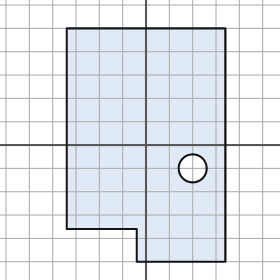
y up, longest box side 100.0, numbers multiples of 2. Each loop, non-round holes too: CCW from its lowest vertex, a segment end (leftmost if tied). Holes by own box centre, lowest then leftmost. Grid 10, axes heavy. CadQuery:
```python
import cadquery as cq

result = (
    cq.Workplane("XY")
    .moveTo(-4.0, -50.0)
    .lineTo(34.0, -50.0)
    .lineTo(34.0, 50.0)
    .lineTo(-34.0, 50.0)
    .lineTo(-34.0, -36.0)
    .lineTo(-4.0, -36.0)
    .close()
    .moveTo(20.0, -10.0)
    .circle(6.0)
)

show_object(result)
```